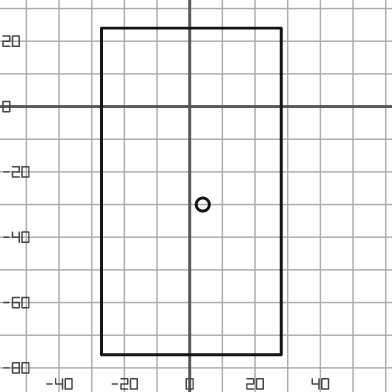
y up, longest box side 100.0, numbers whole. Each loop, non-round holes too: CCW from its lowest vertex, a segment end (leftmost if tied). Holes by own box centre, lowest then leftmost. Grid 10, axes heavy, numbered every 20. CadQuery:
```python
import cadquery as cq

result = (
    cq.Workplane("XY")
    .moveTo(-27.0, -76.0)
    .lineTo(28.0, -76.0)
    .lineTo(28.0, 24.0)
    .lineTo(-27.0, 24.0)
    .close()
    .moveTo(4.0, -30.0)
    .circle(2.0)
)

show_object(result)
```